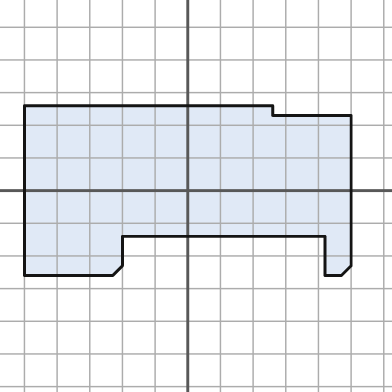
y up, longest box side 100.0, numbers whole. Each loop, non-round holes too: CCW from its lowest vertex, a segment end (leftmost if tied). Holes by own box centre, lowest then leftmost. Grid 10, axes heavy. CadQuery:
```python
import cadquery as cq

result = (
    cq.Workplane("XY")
    .moveTo(-50.0, -26.0)
    .lineTo(-23.0, -26.0)
    .lineTo(-20.0, -23.0)
    .lineTo(-20.0, -14.0)
    .lineTo(42.0, -14.0)
    .lineTo(42.0, -26.0)
    .lineTo(47.0, -26.0)
    .lineTo(50.0, -23.0)
    .lineTo(50.0, 23.0)
    .lineTo(26.0, 23.0)
    .lineTo(26.0, 26.0)
    .lineTo(-50.0, 26.0)
    .close()
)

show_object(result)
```